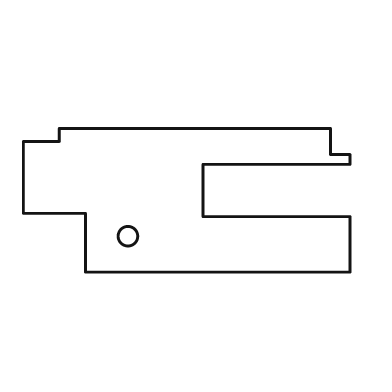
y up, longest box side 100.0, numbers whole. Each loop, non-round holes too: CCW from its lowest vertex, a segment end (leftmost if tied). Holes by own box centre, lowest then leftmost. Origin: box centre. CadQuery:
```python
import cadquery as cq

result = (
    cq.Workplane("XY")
    .moveTo(-31.0, -22.0)
    .lineTo(50.0, -22.0)
    .lineTo(50.0, -5.0)
    .lineTo(5.0, -5.0)
    .lineTo(5.0, 11.0)
    .lineTo(50.0, 11.0)
    .lineTo(50.0, 14.0)
    .lineTo(44.0, 14.0)
    .lineTo(44.0, 22.0)
    .lineTo(-39.0, 22.0)
    .lineTo(-39.0, 18.0)
    .lineTo(-50.0, 18.0)
    .lineTo(-50.0, -4.0)
    .lineTo(-31.0, -4.0)
    .close()
    .moveTo(-18.0, -11.0)
    .circle(3.0)
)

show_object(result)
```